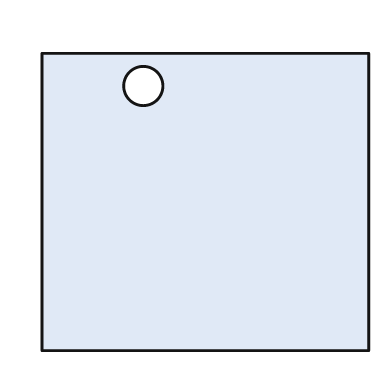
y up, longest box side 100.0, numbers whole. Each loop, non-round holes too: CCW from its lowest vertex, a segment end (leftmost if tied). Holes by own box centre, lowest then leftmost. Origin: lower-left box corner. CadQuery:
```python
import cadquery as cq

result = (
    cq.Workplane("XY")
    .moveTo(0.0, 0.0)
    .lineTo(100.0, 0.0)
    .lineTo(100.0, 91.0)
    .lineTo(0.0, 91.0)
    .close()
    .moveTo(31.0, 81.0)
    .circle(6.0)
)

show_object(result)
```